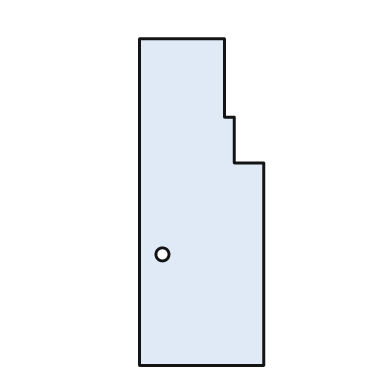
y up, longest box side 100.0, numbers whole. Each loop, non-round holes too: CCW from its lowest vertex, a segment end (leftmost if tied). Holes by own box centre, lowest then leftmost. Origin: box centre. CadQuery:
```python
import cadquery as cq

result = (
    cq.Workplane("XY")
    .moveTo(-19.0, -50.0)
    .lineTo(19.0, -50.0)
    .lineTo(19.0, 12.0)
    .lineTo(10.0, 12.0)
    .lineTo(10.0, 26.0)
    .lineTo(7.0, 26.0)
    .lineTo(7.0, 50.0)
    .lineTo(-19.0, 50.0)
    .close()
    .moveTo(-12.0, -16.0)
    .circle(2.0)
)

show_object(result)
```